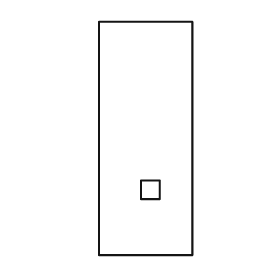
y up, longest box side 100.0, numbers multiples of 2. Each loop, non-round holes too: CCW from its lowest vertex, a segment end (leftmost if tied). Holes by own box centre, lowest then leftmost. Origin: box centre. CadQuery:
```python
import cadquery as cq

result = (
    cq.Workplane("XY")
    .moveTo(-20.0, -50.0)
    .lineTo(20.0, -50.0)
    .lineTo(20.0, 50.0)
    .lineTo(-20.0, 50.0)
    .close()
    .moveTo(-2.0, -26.0)
    .lineTo(6.0, -26.0)
    .lineTo(6.0, -18.0)
    .lineTo(-2.0, -18.0)
    .close()
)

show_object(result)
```